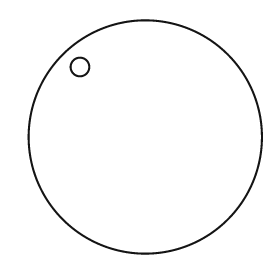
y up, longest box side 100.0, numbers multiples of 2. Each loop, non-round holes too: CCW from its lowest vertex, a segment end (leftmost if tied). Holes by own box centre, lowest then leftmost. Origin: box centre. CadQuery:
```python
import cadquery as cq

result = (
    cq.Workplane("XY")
    .moveTo(0.0, 0.0)
    .circle(50.0)
    .moveTo(-28.0, 30.0)
    .circle(4.0)
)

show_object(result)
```